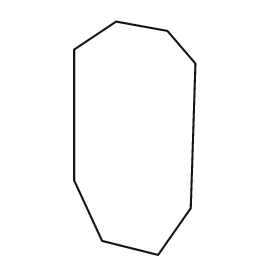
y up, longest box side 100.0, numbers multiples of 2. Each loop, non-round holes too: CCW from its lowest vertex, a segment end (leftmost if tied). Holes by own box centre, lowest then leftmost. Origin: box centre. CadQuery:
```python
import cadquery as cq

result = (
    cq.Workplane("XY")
    .moveTo(10.0, -50.0)
    .lineTo(24.0, -30.0)
    .lineTo(26.0, 32.0)
    .lineTo(14.0, 46.0)
    .lineTo(-8.0, 50.0)
    .lineTo(-26.0, 38.0)
    .lineTo(-26.0, -18.0)
    .lineTo(-14.0, -44.0)
    .close()
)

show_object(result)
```